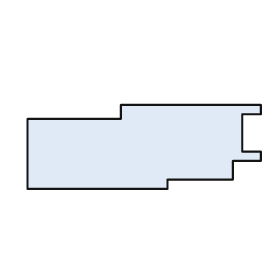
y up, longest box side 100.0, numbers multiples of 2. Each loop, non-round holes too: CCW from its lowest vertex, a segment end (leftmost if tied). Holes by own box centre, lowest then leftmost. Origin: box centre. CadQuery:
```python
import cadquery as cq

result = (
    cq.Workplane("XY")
    .moveTo(-50.0, -18.0)
    .lineTo(10.0, -18.0)
    .lineTo(10.0, -14.0)
    .lineTo(38.0, -14.0)
    .lineTo(38.0, -6.0)
    .lineTo(50.0, -6.0)
    .lineTo(50.0, -2.0)
    .lineTo(42.0, -2.0)
    .lineTo(42.0, 14.0)
    .lineTo(50.0, 14.0)
    .lineTo(50.0, 18.0)
    .lineTo(-10.0, 18.0)
    .lineTo(-10.0, 12.0)
    .lineTo(-50.0, 12.0)
    .close()
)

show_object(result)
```